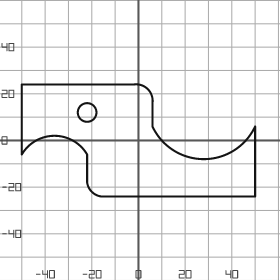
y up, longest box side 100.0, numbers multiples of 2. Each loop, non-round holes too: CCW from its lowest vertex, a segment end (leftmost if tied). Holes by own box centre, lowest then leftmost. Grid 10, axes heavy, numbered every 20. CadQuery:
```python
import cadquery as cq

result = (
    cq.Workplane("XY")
    .moveTo(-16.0, -24.0)
    .lineTo(50.0, -24.0)
    .lineTo(50.0, 6.0)
    .threePointArc((28.0, -8.0), (6.0, 6.0))
    .lineTo(6.0, 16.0)
    .threePointArc((4.0, 22.0), (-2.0, 24.0))
    .lineTo(-50.0, 24.0)
    .lineTo(-50.0, -6.0)
    .threePointArc((-36.0, 2.0), (-22.0, -6.0))
    .lineTo(-22.0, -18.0)
    .threePointArc((-20.0, -22.0), (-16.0, -24.0))
    .close()
    .moveTo(-22.0, 12.0)
    .circle(4.0)
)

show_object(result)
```